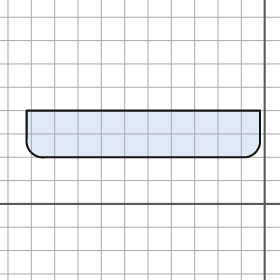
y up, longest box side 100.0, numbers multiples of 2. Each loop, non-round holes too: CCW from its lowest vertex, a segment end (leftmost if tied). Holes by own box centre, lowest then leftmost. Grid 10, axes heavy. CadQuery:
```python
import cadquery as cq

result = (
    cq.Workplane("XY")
    .moveTo(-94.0, 20.0)
    .lineTo(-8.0, 20.0)
    .threePointArc((-4.0, 22.0), (-2.0, 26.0))
    .lineTo(-2.0, 40.0)
    .lineTo(-102.0, 40.0)
    .lineTo(-102.0, 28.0)
    .threePointArc((-100.0, 22.0), (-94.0, 20.0))
    .close()
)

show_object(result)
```